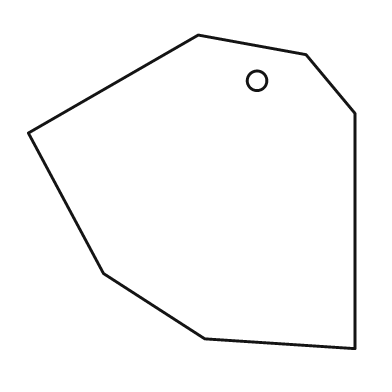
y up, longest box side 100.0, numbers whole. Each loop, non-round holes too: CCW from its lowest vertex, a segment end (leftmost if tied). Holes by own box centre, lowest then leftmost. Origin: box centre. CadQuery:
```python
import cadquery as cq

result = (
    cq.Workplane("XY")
    .moveTo(50.0, -48.0)
    .lineTo(50.0, 24.0)
    .lineTo(35.0, 42.0)
    .lineTo(2.0, 48.0)
    .lineTo(-50.0, 18.0)
    .lineTo(-27.0, -25.0)
    .lineTo(4.0, -45.0)
    .close()
    .moveTo(20.0, 34.0)
    .circle(3.0)
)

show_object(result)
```